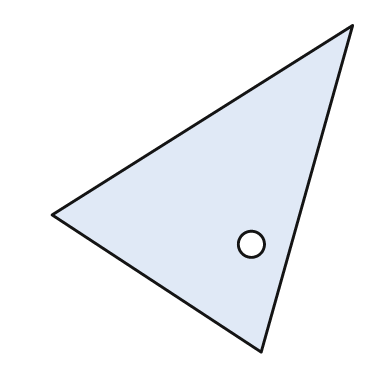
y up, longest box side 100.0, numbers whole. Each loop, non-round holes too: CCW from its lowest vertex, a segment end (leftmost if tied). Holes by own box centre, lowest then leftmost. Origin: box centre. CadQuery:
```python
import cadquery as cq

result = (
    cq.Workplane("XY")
    .moveTo(18.0, -50.0)
    .lineTo(46.0, 50.0)
    .lineTo(-46.0, -8.0)
    .close()
    .moveTo(15.0, -17.0)
    .circle(4.0)
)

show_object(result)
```